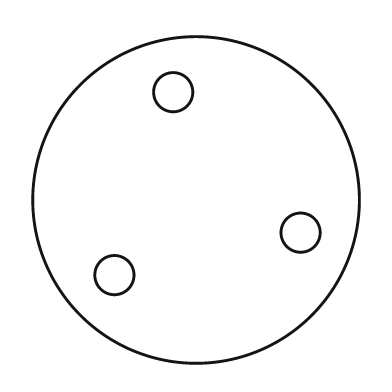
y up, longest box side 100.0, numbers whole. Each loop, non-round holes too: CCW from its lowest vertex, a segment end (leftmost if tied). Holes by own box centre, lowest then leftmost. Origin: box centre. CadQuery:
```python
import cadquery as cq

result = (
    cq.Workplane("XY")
    .moveTo(0.0, 0.0)
    .circle(50.0)
    .moveTo(-25.0, -23.0)
    .circle(6.0)
    .moveTo(32.0, -10.0)
    .circle(6.0)
    .moveTo(-7.0, 33.0)
    .circle(6.0)
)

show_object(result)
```